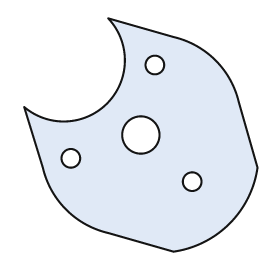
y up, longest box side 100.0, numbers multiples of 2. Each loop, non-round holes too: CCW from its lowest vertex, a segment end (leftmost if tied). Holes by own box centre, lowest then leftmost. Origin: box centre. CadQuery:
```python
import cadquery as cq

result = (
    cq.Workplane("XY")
    .moveTo(14.0, -50.0)
    .threePointArc((38.0, -38.0), (50.0, -14.0))
    .lineTo(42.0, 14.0)
    .threePointArc((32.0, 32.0), (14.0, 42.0))
    .lineTo(-14.0, 50.0)
    .threePointArc((-14.0, 14.0), (-50.0, 12.0))
    .lineTo(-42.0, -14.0)
    .threePointArc((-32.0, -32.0), (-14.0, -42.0))
    .close()
    .moveTo(22.0, -20.0)
    .circle(4.0)
    .moveTo(-30.0, -10.0)
    .circle(4.0)
    .moveTo(0.0, 0.0)
    .circle(8.0)
    .moveTo(6.0, 30.0)
    .circle(4.0)
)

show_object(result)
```